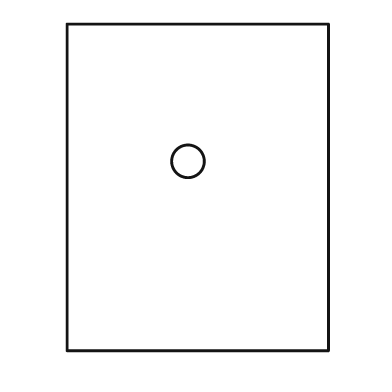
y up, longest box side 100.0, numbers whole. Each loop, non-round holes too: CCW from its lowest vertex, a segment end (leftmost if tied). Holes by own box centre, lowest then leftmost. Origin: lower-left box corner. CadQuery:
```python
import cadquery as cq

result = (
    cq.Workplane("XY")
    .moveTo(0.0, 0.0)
    .lineTo(80.0, 0.0)
    .lineTo(80.0, 100.0)
    .lineTo(0.0, 100.0)
    .close()
    .moveTo(37.0, 58.0)
    .circle(5.0)
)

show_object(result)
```